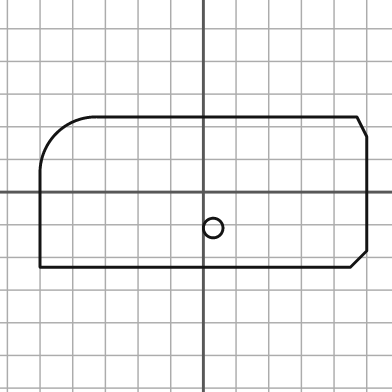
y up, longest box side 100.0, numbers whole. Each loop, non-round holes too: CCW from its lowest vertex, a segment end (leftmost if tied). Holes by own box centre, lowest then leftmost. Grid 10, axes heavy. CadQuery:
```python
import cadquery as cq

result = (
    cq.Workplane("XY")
    .moveTo(-50.0, -23.0)
    .lineTo(45.0, -23.0)
    .lineTo(50.0, -18.0)
    .lineTo(50.0, 17.0)
    .lineTo(47.0, 23.0)
    .lineTo(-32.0, 23.0)
    .threePointArc((-45.0, 18.0), (-50.0, 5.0))
    .close()
    .moveTo(3.0, -11.0)
    .circle(3.0)
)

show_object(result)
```